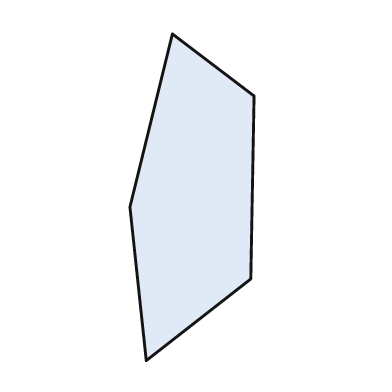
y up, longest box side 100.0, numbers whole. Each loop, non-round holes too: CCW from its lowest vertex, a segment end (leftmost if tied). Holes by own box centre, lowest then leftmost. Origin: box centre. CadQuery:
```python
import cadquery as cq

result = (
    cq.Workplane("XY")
    .moveTo(-14.0, -50.0)
    .lineTo(18.0, -25.0)
    .lineTo(19.0, 31.0)
    .lineTo(-6.0, 50.0)
    .lineTo(-19.0, -3.0)
    .close()
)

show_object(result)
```